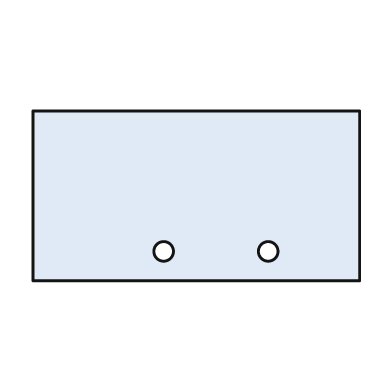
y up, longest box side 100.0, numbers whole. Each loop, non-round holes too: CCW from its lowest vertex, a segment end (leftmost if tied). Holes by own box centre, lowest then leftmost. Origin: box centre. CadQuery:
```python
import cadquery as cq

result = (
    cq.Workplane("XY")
    .moveTo(-50.0, -26.0)
    .lineTo(50.0, -26.0)
    .lineTo(50.0, 26.0)
    .lineTo(-50.0, 26.0)
    .close()
    .moveTo(-10.0, -17.0)
    .circle(3.0)
    .moveTo(22.0, -17.0)
    .circle(3.0)
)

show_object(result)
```